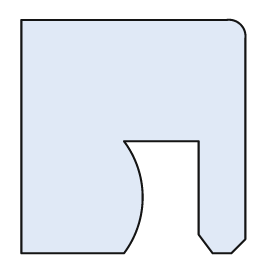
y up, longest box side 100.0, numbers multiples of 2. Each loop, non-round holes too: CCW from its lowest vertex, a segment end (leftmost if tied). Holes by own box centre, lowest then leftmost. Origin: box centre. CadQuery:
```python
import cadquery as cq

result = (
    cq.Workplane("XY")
    .moveTo(-48.0, -50.0)
    .lineTo(-4.0, -50.0)
    .threePointArc((4.0, -26.0), (-4.0, -2.0))
    .lineTo(28.0, -2.0)
    .lineTo(28.0, -42.0)
    .lineTo(34.0, -50.0)
    .lineTo(42.0, -50.0)
    .lineTo(48.0, -44.0)
    .lineTo(48.0, 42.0)
    .threePointArc((46.0, 48.0), (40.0, 50.0))
    .lineTo(-48.0, 50.0)
    .close()
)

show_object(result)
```